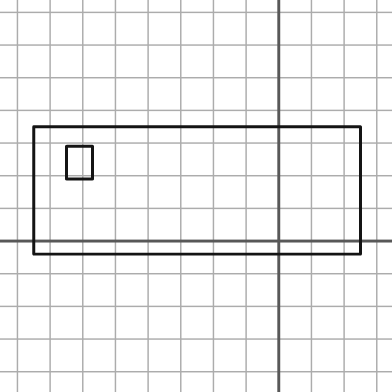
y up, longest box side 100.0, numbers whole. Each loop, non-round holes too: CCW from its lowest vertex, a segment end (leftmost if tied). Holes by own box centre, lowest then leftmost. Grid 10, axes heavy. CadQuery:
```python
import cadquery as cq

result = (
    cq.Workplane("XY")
    .moveTo(-75.0, -4.0)
    .lineTo(25.0, -4.0)
    .lineTo(25.0, 35.0)
    .lineTo(-75.0, 35.0)
    .close()
    .moveTo(-65.0, 19.0)
    .lineTo(-57.0, 19.0)
    .lineTo(-57.0, 29.0)
    .lineTo(-65.0, 29.0)
    .close()
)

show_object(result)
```